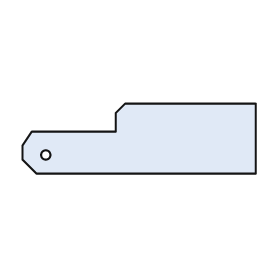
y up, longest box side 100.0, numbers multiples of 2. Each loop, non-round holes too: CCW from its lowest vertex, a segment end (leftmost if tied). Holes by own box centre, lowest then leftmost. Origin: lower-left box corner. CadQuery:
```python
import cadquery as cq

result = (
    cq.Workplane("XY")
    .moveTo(6.0, 0.0)
    .lineTo(100.0, 0.0)
    .lineTo(100.0, 30.0)
    .lineTo(44.0, 30.0)
    .lineTo(40.0, 26.0)
    .lineTo(40.0, 18.0)
    .lineTo(4.0, 18.0)
    .lineTo(0.0, 12.0)
    .lineTo(0.0, 6.0)
    .close()
    .moveTo(10.0, 8.0)
    .circle(2.0)
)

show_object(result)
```